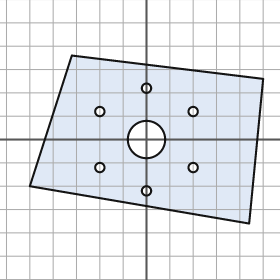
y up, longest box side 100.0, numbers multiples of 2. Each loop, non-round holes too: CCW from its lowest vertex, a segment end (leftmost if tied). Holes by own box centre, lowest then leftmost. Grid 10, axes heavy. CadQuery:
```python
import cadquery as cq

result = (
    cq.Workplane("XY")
    .moveTo(44.0, -36.0)
    .lineTo(50.0, 26.0)
    .lineTo(-32.0, 36.0)
    .lineTo(-50.0, -20.0)
    .close()
    .moveTo(0.0, -22.0)
    .circle(2.0)
    .moveTo(-20.0, -12.0)
    .circle(2.0)
    .moveTo(20.0, -12.0)
    .circle(2.0)
    .moveTo(0.0, 0.0)
    .circle(8.0)
    .moveTo(-20.0, 12.0)
    .circle(2.0)
    .moveTo(20.0, 12.0)
    .circle(2.0)
    .moveTo(0.0, 22.0)
    .circle(2.0)
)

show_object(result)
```